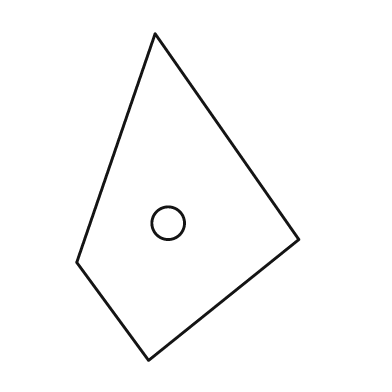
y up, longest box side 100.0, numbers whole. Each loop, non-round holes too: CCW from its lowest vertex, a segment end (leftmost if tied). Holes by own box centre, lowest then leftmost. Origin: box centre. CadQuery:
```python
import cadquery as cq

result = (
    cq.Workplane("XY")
    .moveTo(-12.0, -50.0)
    .lineTo(34.0, -13.0)
    .lineTo(-10.0, 50.0)
    .lineTo(-34.0, -20.0)
    .close()
    .moveTo(-6.0, -8.0)
    .circle(5.0)
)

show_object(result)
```